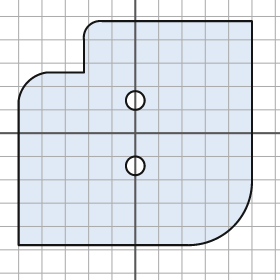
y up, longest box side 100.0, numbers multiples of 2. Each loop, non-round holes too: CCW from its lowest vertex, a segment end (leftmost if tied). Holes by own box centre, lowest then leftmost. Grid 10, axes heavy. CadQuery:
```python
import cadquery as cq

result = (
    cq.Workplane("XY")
    .moveTo(-50.0, -48.0)
    .lineTo(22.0, -48.0)
    .threePointArc((42.0, -40.0), (50.0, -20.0))
    .lineTo(50.0, 48.0)
    .lineTo(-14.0, 48.0)
    .threePointArc((-20.0, 46.0), (-22.0, 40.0))
    .lineTo(-22.0, 26.0)
    .lineTo(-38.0, 26.0)
    .threePointArc((-46.0, 22.0), (-50.0, 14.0))
    .close()
    .moveTo(0.0, -14.0)
    .circle(4.0)
    .moveTo(0.0, 14.0)
    .circle(4.0)
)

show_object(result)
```